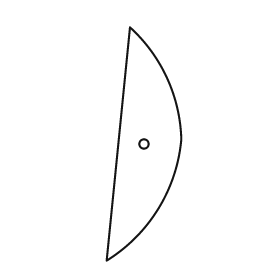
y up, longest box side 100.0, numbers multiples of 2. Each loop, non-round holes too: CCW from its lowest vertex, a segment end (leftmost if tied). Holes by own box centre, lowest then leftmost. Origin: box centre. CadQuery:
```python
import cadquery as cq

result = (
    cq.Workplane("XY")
    .moveTo(-16.0, -50.0)
    .threePointArc((6.0, -28.0), (16.0, 2.0))
    .threePointArc((10.0, 28.0), (-6.0, 50.0))
    .close()
    .moveTo(0.0, 0.0)
    .circle(2.0)
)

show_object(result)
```